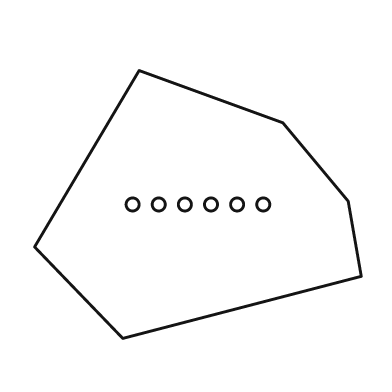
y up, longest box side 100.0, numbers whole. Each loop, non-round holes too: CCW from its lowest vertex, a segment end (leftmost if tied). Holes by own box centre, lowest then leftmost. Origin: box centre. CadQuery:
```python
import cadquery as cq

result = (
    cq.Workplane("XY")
    .moveTo(-23.0, -41.0)
    .lineTo(50.0, -22.0)
    .lineTo(46.0, 1.0)
    .lineTo(26.0, 25.0)
    .lineTo(-18.0, 41.0)
    .lineTo(-50.0, -13.0)
    .close()
    .moveTo(-20.0, 0.0)
    .circle(2.0)
    .moveTo(-12.0, 0.0)
    .circle(2.0)
    .moveTo(-4.0, 0.0)
    .circle(2.0)
    .moveTo(4.0, 0.0)
    .circle(2.0)
    .moveTo(12.0, 0.0)
    .circle(2.0)
    .moveTo(20.0, 0.0)
    .circle(2.0)
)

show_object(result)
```